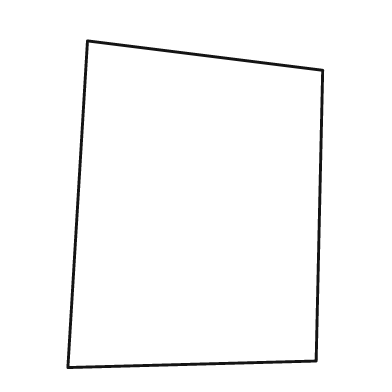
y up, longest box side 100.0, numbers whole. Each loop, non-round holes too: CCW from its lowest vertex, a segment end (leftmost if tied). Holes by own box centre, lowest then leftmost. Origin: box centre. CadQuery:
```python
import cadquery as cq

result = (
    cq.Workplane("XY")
    .moveTo(-39.0, -50.0)
    .lineTo(37.0, -48.0)
    .lineTo(39.0, 41.0)
    .lineTo(-33.0, 50.0)
    .close()
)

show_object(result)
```